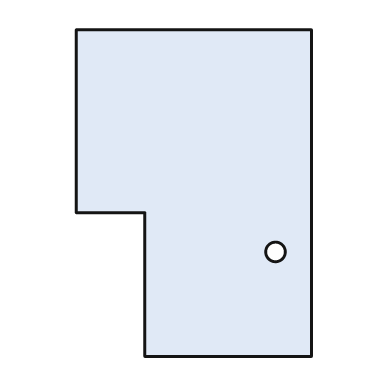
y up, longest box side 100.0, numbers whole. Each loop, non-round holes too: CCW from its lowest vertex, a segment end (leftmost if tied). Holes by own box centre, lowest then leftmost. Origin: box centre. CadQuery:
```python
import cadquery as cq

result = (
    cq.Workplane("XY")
    .moveTo(-15.0, -50.0)
    .lineTo(36.0, -50.0)
    .lineTo(36.0, 50.0)
    .lineTo(-36.0, 50.0)
    .lineTo(-36.0, -6.0)
    .lineTo(-15.0, -6.0)
    .close()
    .moveTo(25.0, -18.0)
    .circle(3.0)
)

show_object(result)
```